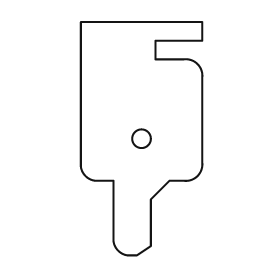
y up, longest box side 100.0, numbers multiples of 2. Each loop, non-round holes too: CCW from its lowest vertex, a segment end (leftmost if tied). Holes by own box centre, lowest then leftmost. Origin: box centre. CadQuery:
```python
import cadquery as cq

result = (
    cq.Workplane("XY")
    .moveTo(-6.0, -50.0)
    .lineTo(-2.0, -50.0)
    .lineTo(4.0, -46.0)
    .lineTo(4.0, -26.0)
    .lineTo(12.0, -18.0)
    .lineTo(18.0, -18.0)
    .threePointArc((24.0, -16.0), (26.0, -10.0))
    .lineTo(26.0, 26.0)
    .threePointArc((24.0, 32.0), (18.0, 34.0))
    .lineTo(6.0, 34.0)
    .lineTo(6.0, 42.0)
    .lineTo(26.0, 42.0)
    .lineTo(26.0, 50.0)
    .lineTo(-26.0, 50.0)
    .lineTo(-26.0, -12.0)
    .threePointArc((-24.0, -16.0), (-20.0, -18.0))
    .lineTo(-12.0, -18.0)
    .lineTo(-12.0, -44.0)
    .threePointArc((-10.0, -48.0), (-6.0, -50.0))
    .close()
    .moveTo(0.0, 0.0)
    .circle(4.0)
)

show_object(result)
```